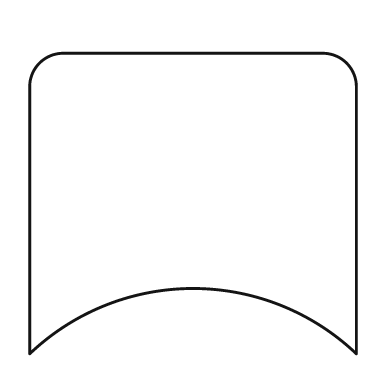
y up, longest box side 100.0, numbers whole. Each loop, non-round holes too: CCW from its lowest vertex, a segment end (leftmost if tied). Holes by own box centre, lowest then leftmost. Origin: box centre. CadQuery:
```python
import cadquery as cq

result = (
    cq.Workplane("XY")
    .moveTo(-50.0, -46.0)
    .threePointArc((0.0, -26.0), (50.0, -46.0))
    .lineTo(50.0, 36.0)
    .threePointArc((47.0, 43.0), (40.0, 46.0))
    .lineTo(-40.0, 46.0)
    .threePointArc((-47.0, 43.0), (-50.0, 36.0))
    .close()
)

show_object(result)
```